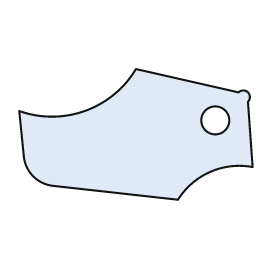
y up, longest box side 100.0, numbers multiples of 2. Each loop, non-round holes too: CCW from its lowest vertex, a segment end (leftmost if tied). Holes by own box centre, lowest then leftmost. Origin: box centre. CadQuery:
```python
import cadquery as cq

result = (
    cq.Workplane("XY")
    .moveTo(18.0, -28.0)
    .threePointArc((32.0, -16.0), (50.0, -14.0))
    .lineTo(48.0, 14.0)
    .threePointArc((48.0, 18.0), (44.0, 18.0))
    .lineTo(0.0, 28.0)
    .threePointArc((-22.0, 10.0), (-50.0, 10.0))
    .lineTo(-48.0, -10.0)
    .threePointArc((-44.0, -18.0), (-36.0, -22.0))
    .close()
    .moveTo(34.0, 6.0)
    .circle(6.0)
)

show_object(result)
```